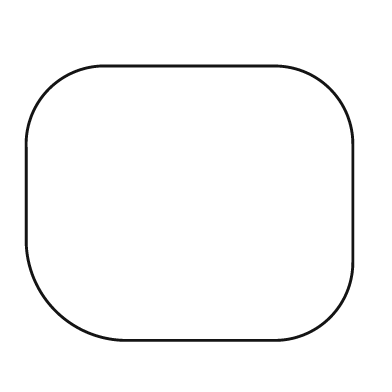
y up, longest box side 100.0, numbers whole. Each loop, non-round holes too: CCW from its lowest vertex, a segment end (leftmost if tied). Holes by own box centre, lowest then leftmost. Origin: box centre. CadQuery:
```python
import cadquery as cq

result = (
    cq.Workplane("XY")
    .moveTo(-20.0, -42.0)
    .lineTo(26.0, -42.0)
    .threePointArc((43.0, -35.0), (50.0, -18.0))
    .lineTo(50.0, 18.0)
    .threePointArc((43.0, 35.0), (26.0, 42.0))
    .lineTo(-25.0, 42.0)
    .threePointArc((-43.0, 35.0), (-50.0, 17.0))
    .lineTo(-50.0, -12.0)
    .threePointArc((-41.0, -33.0), (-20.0, -42.0))
    .close()
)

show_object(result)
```